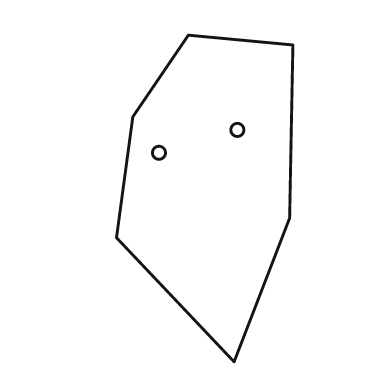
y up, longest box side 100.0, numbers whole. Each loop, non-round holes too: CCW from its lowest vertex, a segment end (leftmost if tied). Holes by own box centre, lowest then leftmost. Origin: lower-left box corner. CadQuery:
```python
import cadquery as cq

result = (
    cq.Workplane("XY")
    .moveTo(36.0, 0.0)
    .lineTo(53.0, 44.0)
    .lineTo(54.0, 97.0)
    .lineTo(22.0, 100.0)
    .lineTo(5.0, 75.0)
    .lineTo(0.0, 38.0)
    .close()
    .moveTo(13.0, 64.0)
    .circle(2.0)
    .moveTo(37.0, 71.0)
    .circle(2.0)
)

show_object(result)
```